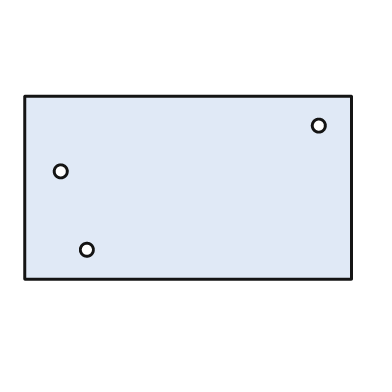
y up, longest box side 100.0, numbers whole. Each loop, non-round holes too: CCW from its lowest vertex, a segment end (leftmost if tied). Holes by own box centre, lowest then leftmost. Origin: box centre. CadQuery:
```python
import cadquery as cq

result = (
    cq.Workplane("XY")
    .moveTo(-50.0, -28.0)
    .lineTo(50.0, -28.0)
    .lineTo(50.0, 28.0)
    .lineTo(-50.0, 28.0)
    .close()
    .moveTo(-31.0, -19.0)
    .circle(2.0)
    .moveTo(-39.0, 5.0)
    .circle(2.0)
    .moveTo(40.0, 19.0)
    .circle(2.0)
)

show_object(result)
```